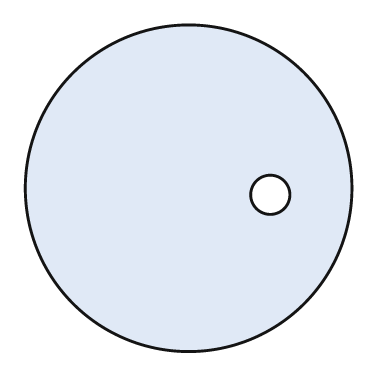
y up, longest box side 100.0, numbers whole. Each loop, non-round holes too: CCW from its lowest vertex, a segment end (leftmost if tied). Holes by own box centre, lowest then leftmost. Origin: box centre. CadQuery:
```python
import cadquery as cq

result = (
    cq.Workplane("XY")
    .moveTo(0.0, 0.0)
    .circle(50.0)
    .moveTo(25.0, -2.0)
    .circle(6.0)
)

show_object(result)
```